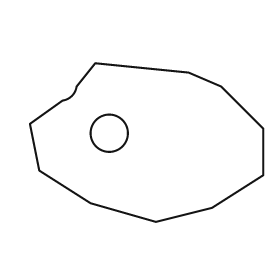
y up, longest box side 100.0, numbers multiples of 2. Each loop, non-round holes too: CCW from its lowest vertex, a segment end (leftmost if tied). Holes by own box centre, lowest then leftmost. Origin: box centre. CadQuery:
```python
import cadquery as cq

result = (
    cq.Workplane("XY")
    .moveTo(4.0, -34.0)
    .lineTo(28.0, -28.0)
    .lineTo(50.0, -14.0)
    .lineTo(50.0, 6.0)
    .lineTo(32.0, 24.0)
    .lineTo(18.0, 30.0)
    .lineTo(-22.0, 34.0)
    .lineTo(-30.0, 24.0)
    .threePointArc((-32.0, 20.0), (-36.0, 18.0))
    .lineTo(-50.0, 8.0)
    .lineTo(-46.0, -12.0)
    .lineTo(-24.0, -26.0)
    .close()
    .moveTo(-16.0, 4.0)
    .circle(8.0)
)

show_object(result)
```